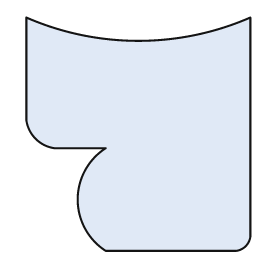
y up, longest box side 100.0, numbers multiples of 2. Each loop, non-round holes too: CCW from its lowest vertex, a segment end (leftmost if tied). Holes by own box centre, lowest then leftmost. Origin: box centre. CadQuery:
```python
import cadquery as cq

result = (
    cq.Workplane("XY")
    .moveTo(-14.0, -50.0)
    .lineTo(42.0, -50.0)
    .threePointArc((46.0, -48.0), (48.0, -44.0))
    .lineTo(48.0, 50.0)
    .threePointArc((0.0, 40.0), (-48.0, 50.0))
    .lineTo(-48.0, 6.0)
    .threePointArc((-44.0, -2.0), (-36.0, -6.0))
    .lineTo(-14.0, -6.0)
    .threePointArc((-26.0, -28.0), (-14.0, -50.0))
    .close()
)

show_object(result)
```